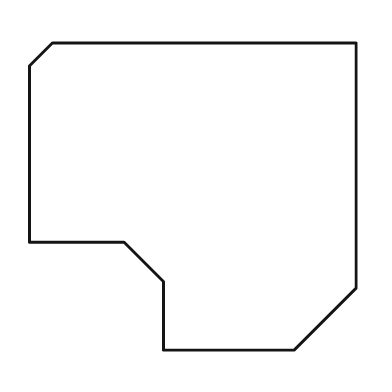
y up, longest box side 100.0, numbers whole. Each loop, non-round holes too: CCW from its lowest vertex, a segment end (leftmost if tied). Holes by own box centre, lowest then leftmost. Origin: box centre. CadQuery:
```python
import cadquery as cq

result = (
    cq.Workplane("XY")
    .moveTo(-9.0, -47.0)
    .lineTo(31.0, -47.0)
    .lineTo(50.0, -28.0)
    .lineTo(50.0, 47.0)
    .lineTo(-43.0, 47.0)
    .lineTo(-50.0, 40.0)
    .lineTo(-50.0, -14.0)
    .lineTo(-21.0, -14.0)
    .lineTo(-9.0, -26.0)
    .close()
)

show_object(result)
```